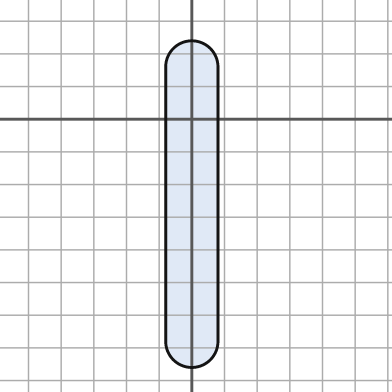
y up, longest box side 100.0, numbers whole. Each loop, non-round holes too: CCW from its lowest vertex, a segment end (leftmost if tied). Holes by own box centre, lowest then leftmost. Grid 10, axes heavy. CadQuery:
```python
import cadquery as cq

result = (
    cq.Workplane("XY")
    .moveTo(-8.0, -68.0)
    .threePointArc((0.0, -76.0), (8.0, -68.0))
    .lineTo(8.0, 16.0)
    .threePointArc((0.0, 24.0), (-8.0, 16.0))
    .close()
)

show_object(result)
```